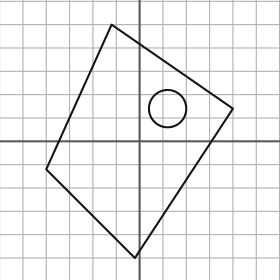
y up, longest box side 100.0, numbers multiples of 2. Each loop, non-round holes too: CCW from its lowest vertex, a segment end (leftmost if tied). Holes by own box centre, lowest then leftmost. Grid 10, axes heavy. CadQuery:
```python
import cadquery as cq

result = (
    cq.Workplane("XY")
    .moveTo(-2.0, -50.0)
    .lineTo(40.0, 14.0)
    .lineTo(-12.0, 50.0)
    .lineTo(-40.0, -12.0)
    .close()
    .moveTo(12.0, 14.0)
    .circle(8.0)
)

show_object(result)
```